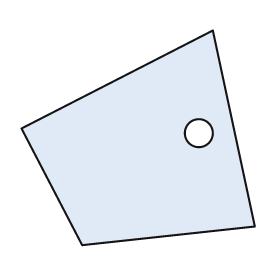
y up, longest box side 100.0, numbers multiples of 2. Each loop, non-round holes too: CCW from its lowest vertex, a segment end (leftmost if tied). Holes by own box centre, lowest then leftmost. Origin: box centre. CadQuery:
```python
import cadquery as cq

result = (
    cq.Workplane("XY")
    .moveTo(-24.0, -46.0)
    .lineTo(50.0, -38.0)
    .lineTo(32.0, 46.0)
    .lineTo(-50.0, 4.0)
    .close()
    .moveTo(26.0, 2.0)
    .circle(6.0)
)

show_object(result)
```